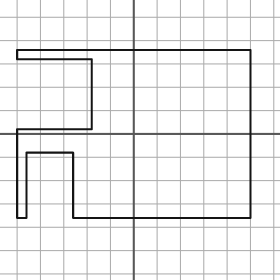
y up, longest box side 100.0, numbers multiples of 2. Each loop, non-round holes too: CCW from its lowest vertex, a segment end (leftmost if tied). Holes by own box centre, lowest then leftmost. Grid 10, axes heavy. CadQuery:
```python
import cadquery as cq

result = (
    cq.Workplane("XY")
    .moveTo(-50.0, -36.0)
    .lineTo(-46.0, -36.0)
    .lineTo(-46.0, -8.0)
    .lineTo(-26.0, -8.0)
    .lineTo(-26.0, -36.0)
    .lineTo(50.0, -36.0)
    .lineTo(50.0, 36.0)
    .lineTo(-50.0, 36.0)
    .lineTo(-50.0, 32.0)
    .lineTo(-18.0, 32.0)
    .lineTo(-18.0, 2.0)
    .lineTo(-50.0, 2.0)
    .close()
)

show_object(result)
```